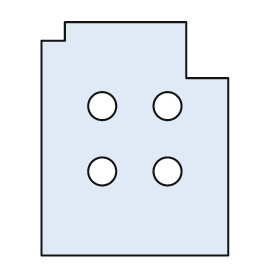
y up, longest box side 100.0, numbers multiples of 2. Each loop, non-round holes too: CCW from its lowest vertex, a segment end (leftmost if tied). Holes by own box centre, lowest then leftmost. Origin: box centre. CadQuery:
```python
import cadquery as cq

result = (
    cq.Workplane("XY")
    .moveTo(-40.0, -50.0)
    .lineTo(40.0, -50.0)
    .lineTo(40.0, 26.0)
    .lineTo(22.0, 26.0)
    .lineTo(22.0, 50.0)
    .lineTo(-30.0, 50.0)
    .lineTo(-30.0, 42.0)
    .lineTo(-40.0, 42.0)
    .close()
    .moveTo(-14.0, -14.0)
    .circle(6.0)
    .moveTo(14.0, -14.0)
    .circle(6.0)
    .moveTo(-14.0, 14.0)
    .circle(6.0)
    .moveTo(14.0, 14.0)
    .circle(6.0)
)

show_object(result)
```